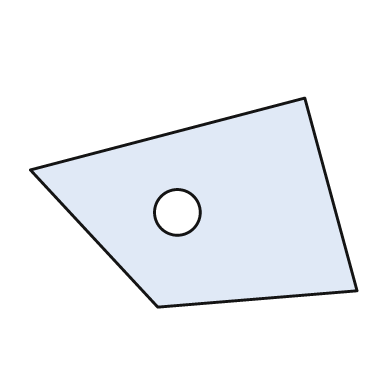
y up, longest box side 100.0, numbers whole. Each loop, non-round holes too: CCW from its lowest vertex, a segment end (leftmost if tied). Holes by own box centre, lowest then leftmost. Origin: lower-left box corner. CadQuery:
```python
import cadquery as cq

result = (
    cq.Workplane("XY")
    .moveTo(39.0, 0.0)
    .lineTo(100.0, 5.0)
    .lineTo(84.0, 64.0)
    .lineTo(0.0, 42.0)
    .close()
    .moveTo(45.0, 29.0)
    .circle(7.0)
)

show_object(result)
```